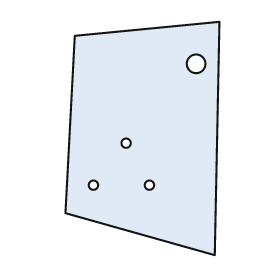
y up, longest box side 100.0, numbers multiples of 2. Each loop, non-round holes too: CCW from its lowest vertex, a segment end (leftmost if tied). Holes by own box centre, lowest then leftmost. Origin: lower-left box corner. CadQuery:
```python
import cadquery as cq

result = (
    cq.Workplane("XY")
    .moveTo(64.0, 0.0)
    .lineTo(66.0, 100.0)
    .lineTo(4.0, 94.0)
    .lineTo(0.0, 18.0)
    .close()
    .moveTo(12.0, 30.0)
    .circle(2.0)
    .moveTo(36.0, 30.0)
    .circle(2.0)
    .moveTo(26.0, 48.0)
    .circle(2.0)
    .moveTo(56.0, 82.0)
    .circle(4.0)
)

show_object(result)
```